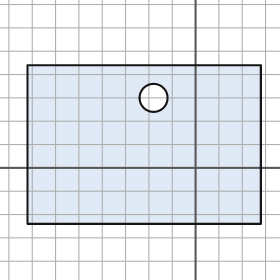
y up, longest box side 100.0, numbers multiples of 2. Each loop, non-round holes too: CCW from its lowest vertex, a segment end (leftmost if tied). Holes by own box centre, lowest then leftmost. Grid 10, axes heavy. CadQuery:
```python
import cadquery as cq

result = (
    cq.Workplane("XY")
    .moveTo(-72.0, -24.0)
    .lineTo(28.0, -24.0)
    .lineTo(28.0, 44.0)
    .lineTo(-72.0, 44.0)
    .close()
    .moveTo(-18.0, 30.0)
    .circle(6.0)
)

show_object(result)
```